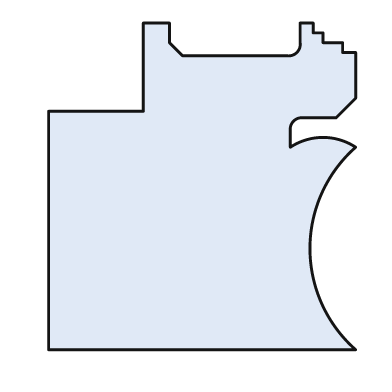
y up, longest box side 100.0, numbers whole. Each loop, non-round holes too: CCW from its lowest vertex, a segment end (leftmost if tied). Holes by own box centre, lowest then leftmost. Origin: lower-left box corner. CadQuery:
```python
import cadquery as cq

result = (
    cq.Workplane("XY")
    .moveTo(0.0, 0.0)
    .lineTo(94.0, 0.0)
    .threePointArc((80.0, 31.0), (94.0, 62.0))
    .threePointArc((84.0, 65.0), (74.0, 62.0))
    .lineTo(74.0, 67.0)
    .threePointArc((75.0, 70.0), (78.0, 71.0))
    .lineTo(88.0, 71.0)
    .lineTo(94.0, 77.0)
    .lineTo(94.0, 91.0)
    .lineTo(90.0, 91.0)
    .lineTo(90.0, 94.0)
    .lineTo(84.0, 94.0)
    .lineTo(84.0, 97.0)
    .lineTo(81.0, 97.0)
    .lineTo(81.0, 100.0)
    .lineTo(77.0, 100.0)
    .lineTo(77.0, 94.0)
    .threePointArc((76.0, 91.0), (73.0, 90.0))
    .lineTo(41.0, 90.0)
    .lineTo(37.0, 94.0)
    .lineTo(37.0, 100.0)
    .lineTo(29.0, 100.0)
    .lineTo(29.0, 73.0)
    .lineTo(0.0, 73.0)
    .close()
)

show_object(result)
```